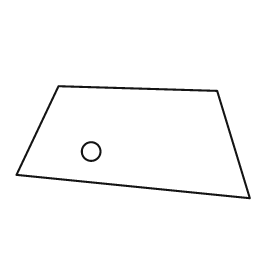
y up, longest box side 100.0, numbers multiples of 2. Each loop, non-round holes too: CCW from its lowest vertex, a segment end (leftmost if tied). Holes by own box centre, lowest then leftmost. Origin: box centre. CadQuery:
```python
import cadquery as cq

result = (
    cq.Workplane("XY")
    .moveTo(50.0, -24.0)
    .lineTo(36.0, 22.0)
    .lineTo(-32.0, 24.0)
    .lineTo(-50.0, -14.0)
    .close()
    .moveTo(-18.0, -4.0)
    .circle(4.0)
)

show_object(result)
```